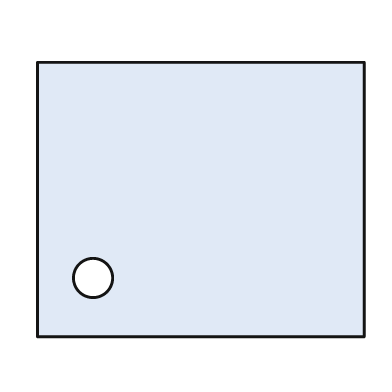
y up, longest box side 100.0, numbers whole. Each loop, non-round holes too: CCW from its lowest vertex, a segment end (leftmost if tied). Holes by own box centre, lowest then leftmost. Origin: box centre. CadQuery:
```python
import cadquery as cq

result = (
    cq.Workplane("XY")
    .moveTo(-50.0, -42.0)
    .lineTo(50.0, -42.0)
    .lineTo(50.0, 42.0)
    .lineTo(-50.0, 42.0)
    .close()
    .moveTo(-33.0, -24.0)
    .circle(6.0)
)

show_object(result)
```